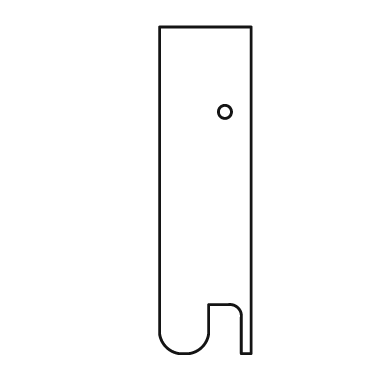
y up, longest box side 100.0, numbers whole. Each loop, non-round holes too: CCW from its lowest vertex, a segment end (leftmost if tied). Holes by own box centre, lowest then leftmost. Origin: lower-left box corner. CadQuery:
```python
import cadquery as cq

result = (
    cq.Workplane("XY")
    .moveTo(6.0, 0.0)
    .lineTo(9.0, 0.0)
    .threePointArc((13.0, 2.0), (15.0, 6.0))
    .lineTo(15.0, 15.0)
    .lineTo(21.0, 15.0)
    .threePointArc((24.0, 14.0), (25.0, 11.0))
    .lineTo(25.0, 0.0)
    .lineTo(28.0, 0.0)
    .lineTo(28.0, 100.0)
    .lineTo(0.0, 100.0)
    .lineTo(0.0, 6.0)
    .threePointArc((2.0, 2.0), (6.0, 0.0))
    .close()
    .moveTo(20.0, 74.0)
    .circle(2.0)
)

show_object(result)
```